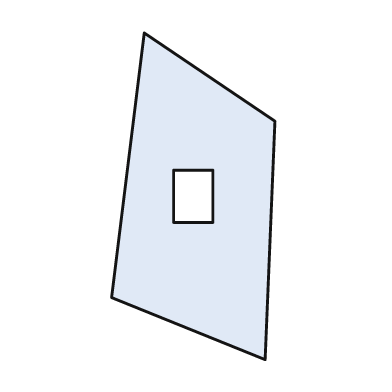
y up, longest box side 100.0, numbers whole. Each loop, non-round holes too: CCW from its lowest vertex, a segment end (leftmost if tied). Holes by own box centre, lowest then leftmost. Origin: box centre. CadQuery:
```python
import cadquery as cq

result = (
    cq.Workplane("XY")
    .moveTo(22.0, -50.0)
    .lineTo(25.0, 23.0)
    .lineTo(-15.0, 50.0)
    .lineTo(-25.0, -31.0)
    .close()
    .moveTo(-6.0, -8.0)
    .lineTo(6.0, -8.0)
    .lineTo(6.0, 8.0)
    .lineTo(-6.0, 8.0)
    .close()
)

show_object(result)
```